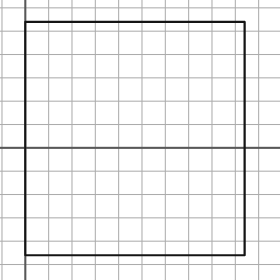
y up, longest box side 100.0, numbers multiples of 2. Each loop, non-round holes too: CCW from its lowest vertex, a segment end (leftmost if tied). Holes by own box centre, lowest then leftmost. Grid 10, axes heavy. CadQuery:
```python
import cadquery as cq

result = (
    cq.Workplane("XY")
    .moveTo(0.0, -46.0)
    .lineTo(94.0, -46.0)
    .lineTo(94.0, 54.0)
    .lineTo(0.0, 54.0)
    .close()
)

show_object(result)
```